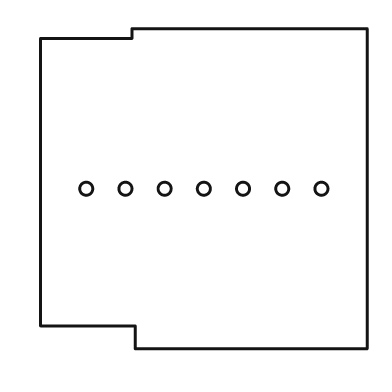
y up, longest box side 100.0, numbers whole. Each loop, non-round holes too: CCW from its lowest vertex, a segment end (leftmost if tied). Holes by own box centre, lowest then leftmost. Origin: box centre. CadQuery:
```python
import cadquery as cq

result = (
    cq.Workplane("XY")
    .moveTo(-21.0, -49.0)
    .lineTo(50.0, -49.0)
    .lineTo(50.0, 49.0)
    .lineTo(-22.0, 49.0)
    .lineTo(-22.0, 46.0)
    .lineTo(-50.0, 46.0)
    .lineTo(-50.0, -42.0)
    .lineTo(-21.0, -42.0)
    .close()
    .moveTo(-36.0, 0.0)
    .circle(2.0)
    .moveTo(-24.0, 0.0)
    .circle(2.0)
    .moveTo(-12.0, 0.0)
    .circle(2.0)
    .moveTo(0.0, 0.0)
    .circle(2.0)
    .moveTo(12.0, 0.0)
    .circle(2.0)
    .moveTo(24.0, 0.0)
    .circle(2.0)
    .moveTo(36.0, 0.0)
    .circle(2.0)
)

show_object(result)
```